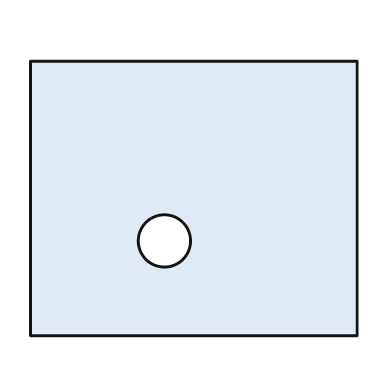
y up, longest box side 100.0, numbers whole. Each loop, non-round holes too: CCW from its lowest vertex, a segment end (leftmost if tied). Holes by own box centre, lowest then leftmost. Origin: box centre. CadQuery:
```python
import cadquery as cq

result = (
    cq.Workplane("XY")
    .moveTo(-50.0, -42.0)
    .lineTo(50.0, -42.0)
    .lineTo(50.0, 42.0)
    .lineTo(-50.0, 42.0)
    .close()
    .moveTo(-9.0, -13.0)
    .circle(8.0)
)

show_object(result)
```